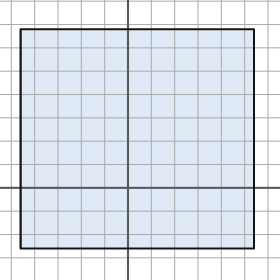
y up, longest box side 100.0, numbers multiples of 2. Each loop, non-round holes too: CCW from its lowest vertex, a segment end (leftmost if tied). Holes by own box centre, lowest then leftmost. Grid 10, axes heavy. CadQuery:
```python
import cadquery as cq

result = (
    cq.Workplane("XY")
    .moveTo(-46.0, -26.0)
    .lineTo(54.0, -26.0)
    .lineTo(54.0, 68.0)
    .lineTo(-46.0, 68.0)
    .close()
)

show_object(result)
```